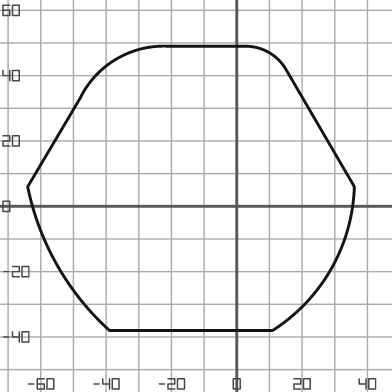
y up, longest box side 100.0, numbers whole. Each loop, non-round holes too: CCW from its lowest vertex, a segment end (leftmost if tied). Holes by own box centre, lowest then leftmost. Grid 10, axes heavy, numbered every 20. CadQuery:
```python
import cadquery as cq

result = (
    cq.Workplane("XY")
    .moveTo(-39.0, -38.0)
    .lineTo(11.0, -38.0)
    .threePointArc((29.0, -19.0), (36.0, 6.0))
    .lineTo(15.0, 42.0)
    .threePointArc((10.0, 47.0), (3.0, 49.0))
    .lineTo(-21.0, 49.0)
    .threePointArc((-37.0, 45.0), (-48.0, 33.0))
    .lineTo(-64.0, 6.0)
    .threePointArc((-55.0, -18.0), (-39.0, -38.0))
    .close()
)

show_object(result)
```